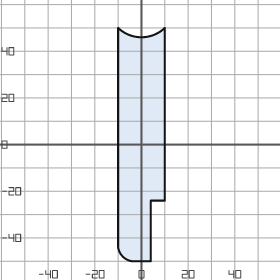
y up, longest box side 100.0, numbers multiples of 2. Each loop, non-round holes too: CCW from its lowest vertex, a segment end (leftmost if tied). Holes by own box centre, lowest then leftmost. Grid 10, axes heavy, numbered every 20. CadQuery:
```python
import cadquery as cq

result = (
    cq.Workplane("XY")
    .moveTo(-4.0, -50.0)
    .lineTo(4.0, -50.0)
    .lineTo(4.0, -24.0)
    .lineTo(10.0, -24.0)
    .lineTo(10.0, 50.0)
    .threePointArc((0.0, 46.0), (-10.0, 50.0))
    .lineTo(-10.0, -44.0)
    .threePointArc((-8.0, -48.0), (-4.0, -50.0))
    .close()
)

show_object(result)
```